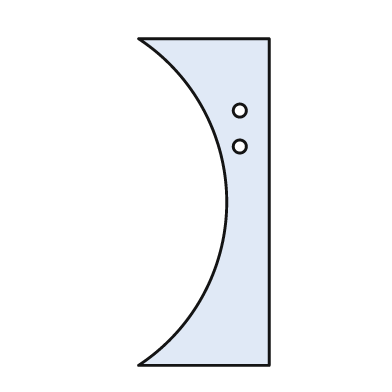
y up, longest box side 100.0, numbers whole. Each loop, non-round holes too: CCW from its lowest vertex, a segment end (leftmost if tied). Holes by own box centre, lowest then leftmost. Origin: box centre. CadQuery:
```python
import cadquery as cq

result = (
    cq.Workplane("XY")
    .moveTo(-20.0, -50.0)
    .lineTo(20.0, -50.0)
    .lineTo(20.0, 50.0)
    .lineTo(-20.0, 50.0)
    .threePointArc((7.0, 0.0), (-20.0, -50.0))
    .close()
    .moveTo(11.0, 17.0)
    .circle(2.0)
    .moveTo(11.0, 28.0)
    .circle(2.0)
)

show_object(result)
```